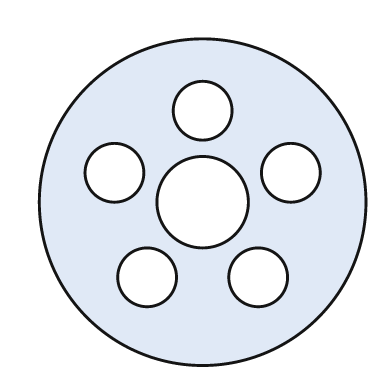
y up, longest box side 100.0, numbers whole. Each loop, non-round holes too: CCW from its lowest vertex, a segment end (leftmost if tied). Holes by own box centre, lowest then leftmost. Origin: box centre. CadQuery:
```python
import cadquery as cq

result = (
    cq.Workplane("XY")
    .moveTo(0.0, 0.0)
    .circle(50.0)
    .moveTo(-17.0, -23.0)
    .circle(9.0)
    .moveTo(17.0, -23.0)
    .circle(9.0)
    .moveTo(0.0, 0.0)
    .circle(14.0)
    .moveTo(-27.0, 9.0)
    .circle(9.0)
    .moveTo(27.0, 9.0)
    .circle(9.0)
    .moveTo(0.0, 28.0)
    .circle(9.0)
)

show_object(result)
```